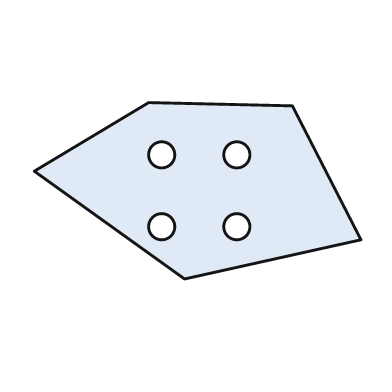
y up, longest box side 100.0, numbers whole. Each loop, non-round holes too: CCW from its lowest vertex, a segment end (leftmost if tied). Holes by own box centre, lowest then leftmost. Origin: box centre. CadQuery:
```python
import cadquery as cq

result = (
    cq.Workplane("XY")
    .moveTo(-4.0, -27.0)
    .lineTo(50.0, -15.0)
    .lineTo(29.0, 26.0)
    .lineTo(-15.0, 27.0)
    .lineTo(-50.0, 6.0)
    .close()
    .moveTo(-11.0, -11.0)
    .circle(4.0)
    .moveTo(12.0, -11.0)
    .circle(4.0)
    .moveTo(-11.0, 11.0)
    .circle(4.0)
    .moveTo(12.0, 11.0)
    .circle(4.0)
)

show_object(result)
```